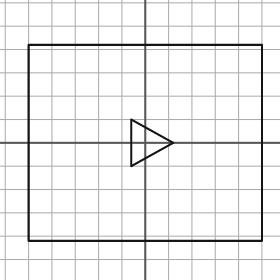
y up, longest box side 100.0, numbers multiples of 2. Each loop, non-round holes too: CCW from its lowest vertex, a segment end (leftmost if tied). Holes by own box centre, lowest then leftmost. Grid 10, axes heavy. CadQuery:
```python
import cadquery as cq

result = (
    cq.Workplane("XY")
    .moveTo(-50.0, -42.0)
    .lineTo(50.0, -42.0)
    .lineTo(50.0, 42.0)
    .lineTo(-50.0, 42.0)
    .close()
    .moveTo(-6.0, -10.0)
    .lineTo(12.0, 0.0)
    .lineTo(-6.0, 10.0)
    .close()
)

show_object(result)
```